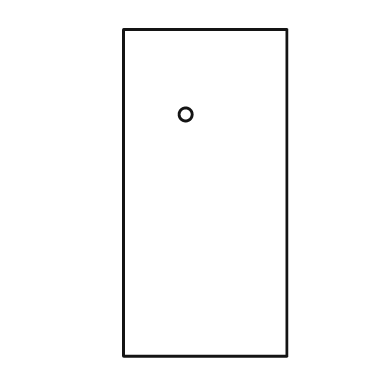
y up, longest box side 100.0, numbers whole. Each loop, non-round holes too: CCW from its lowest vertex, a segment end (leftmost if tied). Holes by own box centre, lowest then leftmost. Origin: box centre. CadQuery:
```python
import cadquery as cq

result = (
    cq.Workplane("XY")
    .moveTo(-25.0, -50.0)
    .lineTo(25.0, -50.0)
    .lineTo(25.0, 50.0)
    .lineTo(-25.0, 50.0)
    .close()
    .moveTo(-6.0, 24.0)
    .circle(2.0)
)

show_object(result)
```